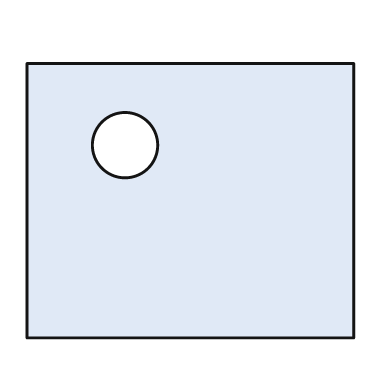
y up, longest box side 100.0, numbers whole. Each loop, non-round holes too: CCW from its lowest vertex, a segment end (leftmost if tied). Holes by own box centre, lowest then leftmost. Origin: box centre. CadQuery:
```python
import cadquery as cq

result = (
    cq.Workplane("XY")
    .moveTo(-50.0, -42.0)
    .lineTo(50.0, -42.0)
    .lineTo(50.0, 42.0)
    .lineTo(-50.0, 42.0)
    .close()
    .moveTo(-20.0, 17.0)
    .circle(10.0)
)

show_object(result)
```